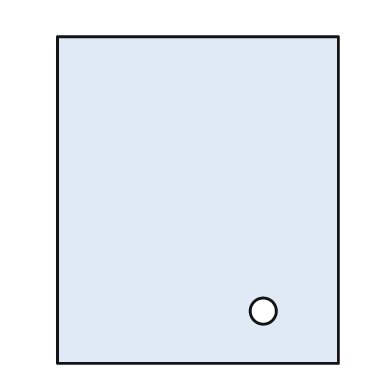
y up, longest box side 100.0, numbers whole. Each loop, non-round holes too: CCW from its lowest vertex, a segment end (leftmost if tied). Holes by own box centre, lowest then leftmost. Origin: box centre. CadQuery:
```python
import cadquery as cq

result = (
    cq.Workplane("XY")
    .moveTo(-43.0, -50.0)
    .lineTo(43.0, -50.0)
    .lineTo(43.0, 50.0)
    .lineTo(-43.0, 50.0)
    .close()
    .moveTo(20.0, -34.0)
    .circle(4.0)
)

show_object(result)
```